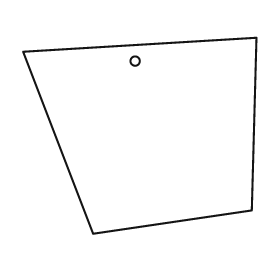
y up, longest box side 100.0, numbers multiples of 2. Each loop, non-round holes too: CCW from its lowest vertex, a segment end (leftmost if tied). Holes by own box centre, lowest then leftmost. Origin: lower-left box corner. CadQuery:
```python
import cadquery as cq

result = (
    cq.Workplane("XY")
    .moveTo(30.0, 0.0)
    .lineTo(98.0, 10.0)
    .lineTo(100.0, 84.0)
    .lineTo(0.0, 78.0)
    .close()
    .moveTo(48.0, 74.0)
    .circle(2.0)
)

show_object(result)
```